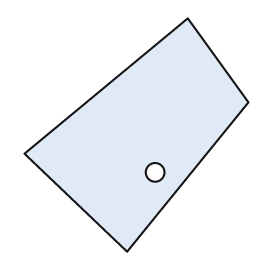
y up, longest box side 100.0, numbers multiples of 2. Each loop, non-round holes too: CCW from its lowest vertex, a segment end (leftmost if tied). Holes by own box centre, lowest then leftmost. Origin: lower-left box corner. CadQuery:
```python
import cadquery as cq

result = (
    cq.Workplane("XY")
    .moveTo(44.0, 0.0)
    .lineTo(96.0, 64.0)
    .lineTo(70.0, 100.0)
    .lineTo(0.0, 42.0)
    .close()
    .moveTo(56.0, 34.0)
    .circle(4.0)
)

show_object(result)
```